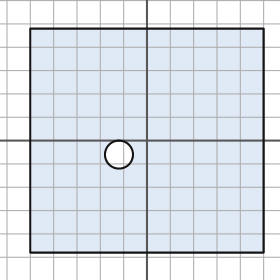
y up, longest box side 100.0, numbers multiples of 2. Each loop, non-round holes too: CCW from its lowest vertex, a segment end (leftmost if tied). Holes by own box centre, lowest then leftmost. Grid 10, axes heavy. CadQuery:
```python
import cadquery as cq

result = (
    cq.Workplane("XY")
    .moveTo(-50.0, -48.0)
    .lineTo(50.0, -48.0)
    .lineTo(50.0, 48.0)
    .lineTo(-50.0, 48.0)
    .close()
    .moveTo(-12.0, -6.0)
    .circle(6.0)
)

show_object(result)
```